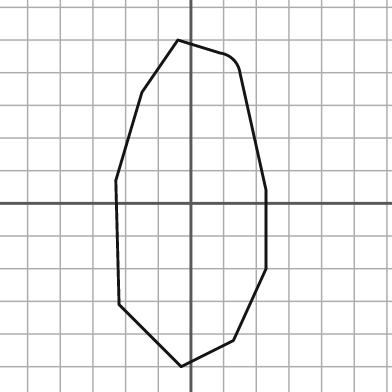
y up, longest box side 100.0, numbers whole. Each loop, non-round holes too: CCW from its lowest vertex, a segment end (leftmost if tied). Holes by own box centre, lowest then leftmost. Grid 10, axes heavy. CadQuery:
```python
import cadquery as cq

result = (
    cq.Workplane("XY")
    .moveTo(-3.0, -50.0)
    .lineTo(13.0, -42.0)
    .lineTo(23.0, -20.0)
    .lineTo(23.0, 4.0)
    .lineTo(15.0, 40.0)
    .threePointArc((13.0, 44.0), (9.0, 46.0))
    .lineTo(-4.0, 50.0)
    .lineTo(-15.0, 34.0)
    .lineTo(-23.0, 7.0)
    .lineTo(-22.0, -31.0)
    .close()
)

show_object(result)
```